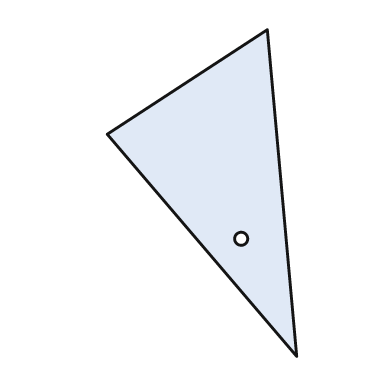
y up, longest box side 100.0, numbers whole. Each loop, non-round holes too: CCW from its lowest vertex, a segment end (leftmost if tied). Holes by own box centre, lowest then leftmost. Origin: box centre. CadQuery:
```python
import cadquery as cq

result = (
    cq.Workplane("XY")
    .moveTo(29.0, -50.0)
    .lineTo(20.0, 50.0)
    .lineTo(-29.0, 18.0)
    .close()
    .moveTo(12.0, -14.0)
    .circle(2.0)
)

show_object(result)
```